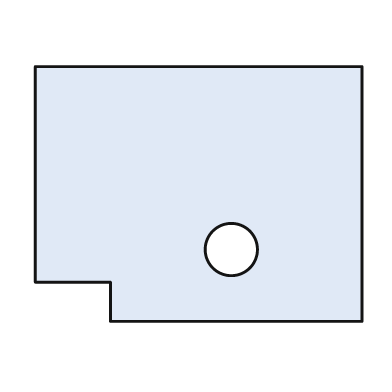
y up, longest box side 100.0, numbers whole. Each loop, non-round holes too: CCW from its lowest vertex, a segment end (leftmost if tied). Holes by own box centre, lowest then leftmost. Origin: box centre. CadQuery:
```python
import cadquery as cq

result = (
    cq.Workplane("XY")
    .moveTo(-27.0, -39.0)
    .lineTo(50.0, -39.0)
    .lineTo(50.0, 39.0)
    .lineTo(-50.0, 39.0)
    .lineTo(-50.0, -27.0)
    .lineTo(-27.0, -27.0)
    .close()
    .moveTo(10.0, -17.0)
    .circle(8.0)
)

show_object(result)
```